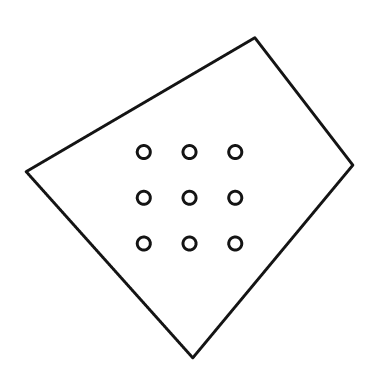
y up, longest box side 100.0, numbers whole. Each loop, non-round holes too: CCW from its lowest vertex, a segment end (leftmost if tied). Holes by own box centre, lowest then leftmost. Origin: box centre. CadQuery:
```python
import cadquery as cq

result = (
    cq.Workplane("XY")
    .moveTo(1.0, -49.0)
    .lineTo(50.0, 10.0)
    .lineTo(20.0, 49.0)
    .lineTo(-50.0, 8.0)
    .close()
    .moveTo(-14.0, -14.0)
    .circle(2.0)
    .moveTo(0.0, -14.0)
    .circle(2.0)
    .moveTo(14.0, -14.0)
    .circle(2.0)
    .moveTo(-14.0, 0.0)
    .circle(2.0)
    .moveTo(0.0, 0.0)
    .circle(2.0)
    .moveTo(14.0, 0.0)
    .circle(2.0)
    .moveTo(-14.0, 14.0)
    .circle(2.0)
    .moveTo(0.0, 14.0)
    .circle(2.0)
    .moveTo(14.0, 14.0)
    .circle(2.0)
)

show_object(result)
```